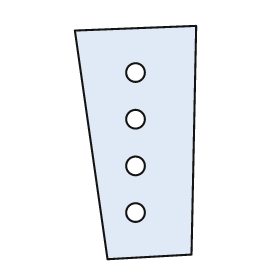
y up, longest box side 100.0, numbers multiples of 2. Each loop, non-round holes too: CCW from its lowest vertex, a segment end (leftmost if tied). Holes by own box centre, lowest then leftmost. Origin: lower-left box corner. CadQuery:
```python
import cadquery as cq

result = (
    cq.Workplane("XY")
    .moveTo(14.0, 0.0)
    .lineTo(50.0, 2.0)
    .lineTo(52.0, 100.0)
    .lineTo(0.0, 98.0)
    .close()
    .moveTo(26.0, 20.0)
    .circle(4.0)
    .moveTo(26.0, 40.0)
    .circle(4.0)
    .moveTo(26.0, 60.0)
    .circle(4.0)
    .moveTo(26.0, 80.0)
    .circle(4.0)
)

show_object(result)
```